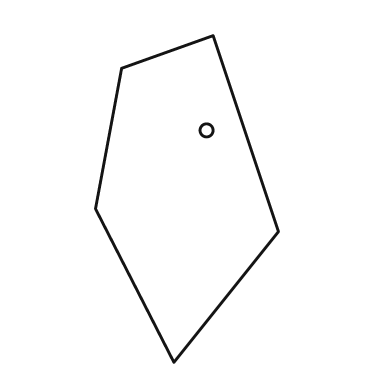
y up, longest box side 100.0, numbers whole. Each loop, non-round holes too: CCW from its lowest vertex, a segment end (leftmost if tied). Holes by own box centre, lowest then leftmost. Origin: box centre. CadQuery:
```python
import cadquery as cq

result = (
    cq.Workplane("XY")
    .moveTo(-4.0, -50.0)
    .lineTo(28.0, -10.0)
    .lineTo(8.0, 50.0)
    .lineTo(-20.0, 40.0)
    .lineTo(-28.0, -3.0)
    .close()
    .moveTo(6.0, 21.0)
    .circle(2.0)
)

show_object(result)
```